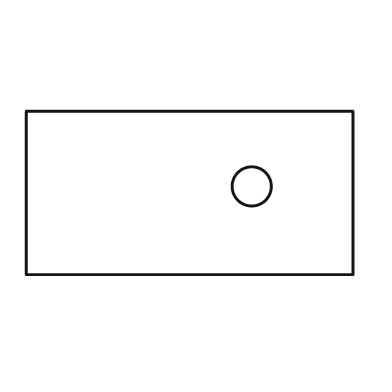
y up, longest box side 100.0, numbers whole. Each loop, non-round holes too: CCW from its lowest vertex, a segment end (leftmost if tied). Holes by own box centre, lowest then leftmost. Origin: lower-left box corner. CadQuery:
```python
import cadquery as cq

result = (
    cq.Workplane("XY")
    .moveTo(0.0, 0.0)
    .lineTo(100.0, 0.0)
    .lineTo(100.0, 50.0)
    .lineTo(0.0, 50.0)
    .close()
    .moveTo(69.0, 27.0)
    .circle(6.0)
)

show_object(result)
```